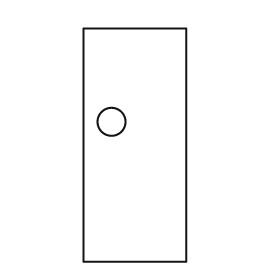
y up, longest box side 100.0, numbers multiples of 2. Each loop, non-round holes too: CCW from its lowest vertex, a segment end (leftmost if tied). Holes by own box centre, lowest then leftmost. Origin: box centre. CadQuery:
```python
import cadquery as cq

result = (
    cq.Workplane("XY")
    .moveTo(-22.0, -50.0)
    .lineTo(22.0, -50.0)
    .lineTo(22.0, 50.0)
    .lineTo(-22.0, 50.0)
    .close()
    .moveTo(-10.0, 10.0)
    .circle(6.0)
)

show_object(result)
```